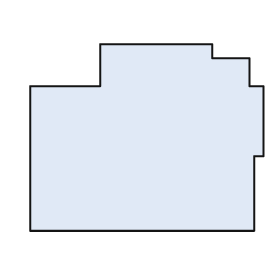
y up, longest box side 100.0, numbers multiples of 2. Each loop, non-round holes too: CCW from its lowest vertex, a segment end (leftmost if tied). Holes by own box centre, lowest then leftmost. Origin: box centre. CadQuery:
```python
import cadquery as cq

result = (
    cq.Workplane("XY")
    .moveTo(-50.0, -40.0)
    .lineTo(46.0, -40.0)
    .lineTo(46.0, -8.0)
    .lineTo(50.0, -8.0)
    .lineTo(50.0, 22.0)
    .lineTo(44.0, 22.0)
    .lineTo(44.0, 34.0)
    .lineTo(28.0, 34.0)
    .lineTo(28.0, 40.0)
    .lineTo(-20.0, 40.0)
    .lineTo(-20.0, 22.0)
    .lineTo(-50.0, 22.0)
    .close()
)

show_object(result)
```